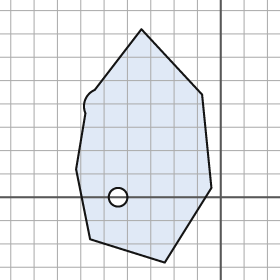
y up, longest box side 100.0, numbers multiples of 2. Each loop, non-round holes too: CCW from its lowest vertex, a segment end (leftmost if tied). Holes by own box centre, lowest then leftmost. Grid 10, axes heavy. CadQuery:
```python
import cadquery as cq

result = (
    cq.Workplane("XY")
    .moveTo(-24.0, -28.0)
    .lineTo(-4.0, 4.0)
    .lineTo(-8.0, 44.0)
    .lineTo(-34.0, 72.0)
    .lineTo(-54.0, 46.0)
    .threePointArc((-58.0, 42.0), (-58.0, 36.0))
    .lineTo(-62.0, 12.0)
    .lineTo(-56.0, -18.0)
    .close()
    .moveTo(-44.0, 0.0)
    .circle(4.0)
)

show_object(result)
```